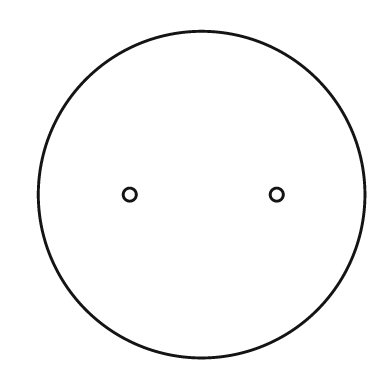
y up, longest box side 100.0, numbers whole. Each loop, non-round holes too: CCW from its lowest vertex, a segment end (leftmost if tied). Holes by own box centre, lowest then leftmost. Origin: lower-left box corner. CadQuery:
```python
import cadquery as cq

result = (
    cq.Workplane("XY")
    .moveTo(50.0, 50.0)
    .circle(50.0)
    .moveTo(28.0, 50.0)
    .circle(2.0)
    .moveTo(73.0, 50.0)
    .circle(2.0)
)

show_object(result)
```